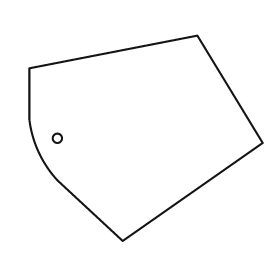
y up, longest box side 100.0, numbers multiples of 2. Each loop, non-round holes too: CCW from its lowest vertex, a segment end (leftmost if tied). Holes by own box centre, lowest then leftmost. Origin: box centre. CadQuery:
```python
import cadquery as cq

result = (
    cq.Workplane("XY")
    .moveTo(-10.0, -44.0)
    .lineTo(50.0, -2.0)
    .lineTo(22.0, 44.0)
    .lineTo(-50.0, 30.0)
    .lineTo(-50.0, 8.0)
    .threePointArc((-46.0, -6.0), (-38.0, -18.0))
    .close()
    .moveTo(-38.0, 0.0)
    .circle(2.0)
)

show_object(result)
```